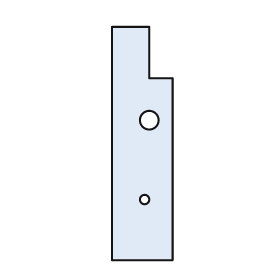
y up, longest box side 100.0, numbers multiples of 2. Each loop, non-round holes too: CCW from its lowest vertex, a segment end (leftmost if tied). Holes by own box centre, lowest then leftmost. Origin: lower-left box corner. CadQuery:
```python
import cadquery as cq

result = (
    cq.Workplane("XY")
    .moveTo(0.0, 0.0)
    .lineTo(26.0, 0.0)
    .lineTo(26.0, 78.0)
    .lineTo(16.0, 78.0)
    .lineTo(16.0, 100.0)
    .lineTo(0.0, 100.0)
    .close()
    .moveTo(14.0, 26.0)
    .circle(2.0)
    .moveTo(16.0, 60.0)
    .circle(4.0)
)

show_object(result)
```